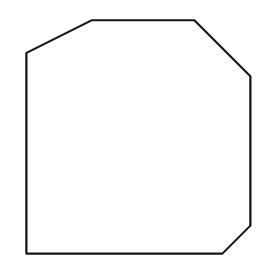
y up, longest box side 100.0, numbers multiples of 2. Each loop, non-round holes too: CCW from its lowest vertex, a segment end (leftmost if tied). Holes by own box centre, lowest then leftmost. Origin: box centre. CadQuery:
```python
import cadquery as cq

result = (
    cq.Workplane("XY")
    .moveTo(-48.0, -50.0)
    .lineTo(36.0, -50.0)
    .lineTo(48.0, -38.0)
    .lineTo(48.0, 26.0)
    .lineTo(24.0, 50.0)
    .lineTo(-20.0, 50.0)
    .lineTo(-48.0, 36.0)
    .close()
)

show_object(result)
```